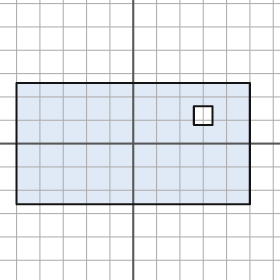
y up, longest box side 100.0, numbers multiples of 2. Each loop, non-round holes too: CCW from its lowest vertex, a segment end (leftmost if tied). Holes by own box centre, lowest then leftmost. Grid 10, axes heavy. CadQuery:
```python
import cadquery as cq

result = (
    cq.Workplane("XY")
    .moveTo(-50.0, -26.0)
    .lineTo(50.0, -26.0)
    .lineTo(50.0, 26.0)
    .lineTo(-50.0, 26.0)
    .close()
    .moveTo(26.0, 8.0)
    .lineTo(34.0, 8.0)
    .lineTo(34.0, 16.0)
    .lineTo(26.0, 16.0)
    .close()
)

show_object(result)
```